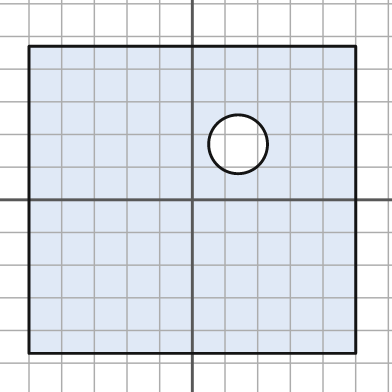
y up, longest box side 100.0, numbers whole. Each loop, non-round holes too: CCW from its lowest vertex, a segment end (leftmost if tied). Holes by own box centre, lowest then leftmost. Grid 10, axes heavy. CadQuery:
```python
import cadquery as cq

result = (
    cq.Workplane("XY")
    .moveTo(-50.0, -47.0)
    .lineTo(50.0, -47.0)
    .lineTo(50.0, 47.0)
    .lineTo(-50.0, 47.0)
    .close()
    .moveTo(14.0, 17.0)
    .circle(9.0)
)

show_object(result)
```